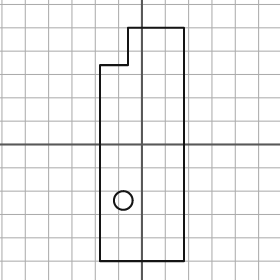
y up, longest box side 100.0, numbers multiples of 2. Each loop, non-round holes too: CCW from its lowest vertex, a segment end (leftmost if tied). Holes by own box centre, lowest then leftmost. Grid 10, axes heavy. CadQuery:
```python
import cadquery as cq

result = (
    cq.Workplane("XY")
    .moveTo(-18.0, -50.0)
    .lineTo(18.0, -50.0)
    .lineTo(18.0, 50.0)
    .lineTo(-6.0, 50.0)
    .lineTo(-6.0, 34.0)
    .lineTo(-18.0, 34.0)
    .close()
    .moveTo(-8.0, -24.0)
    .circle(4.0)
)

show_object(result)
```